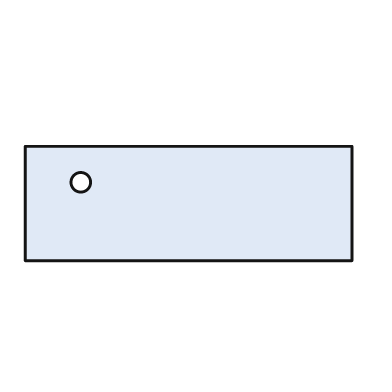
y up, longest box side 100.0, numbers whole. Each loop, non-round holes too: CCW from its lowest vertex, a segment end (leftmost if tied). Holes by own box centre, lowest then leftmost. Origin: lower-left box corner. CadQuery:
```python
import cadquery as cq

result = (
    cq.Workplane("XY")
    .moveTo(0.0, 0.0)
    .lineTo(100.0, 0.0)
    .lineTo(100.0, 35.0)
    .lineTo(0.0, 35.0)
    .close()
    .moveTo(17.0, 24.0)
    .circle(3.0)
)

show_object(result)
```